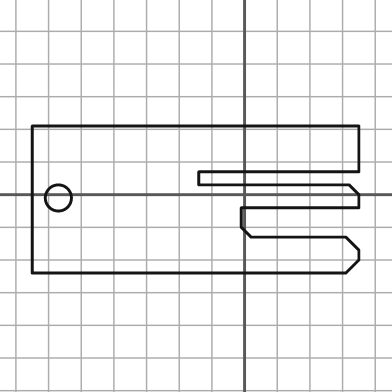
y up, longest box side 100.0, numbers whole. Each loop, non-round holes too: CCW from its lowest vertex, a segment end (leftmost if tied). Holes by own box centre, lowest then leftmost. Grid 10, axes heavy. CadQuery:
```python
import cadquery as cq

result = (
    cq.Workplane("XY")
    .moveTo(-65.0, -24.0)
    .lineTo(31.0, -24.0)
    .lineTo(35.0, -20.0)
    .lineTo(35.0, -17.0)
    .lineTo(31.0, -13.0)
    .lineTo(2.0, -13.0)
    .lineTo(-1.0, -10.0)
    .lineTo(-1.0, -4.0)
    .lineTo(35.0, -4.0)
    .lineTo(35.0, 0.0)
    .lineTo(32.0, 3.0)
    .lineTo(-14.0, 3.0)
    .lineTo(-14.0, 7.0)
    .lineTo(35.0, 7.0)
    .lineTo(35.0, 21.0)
    .lineTo(-65.0, 21.0)
    .close()
    .moveTo(-57.0, -1.0)
    .circle(4.0)
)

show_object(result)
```